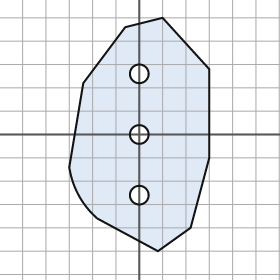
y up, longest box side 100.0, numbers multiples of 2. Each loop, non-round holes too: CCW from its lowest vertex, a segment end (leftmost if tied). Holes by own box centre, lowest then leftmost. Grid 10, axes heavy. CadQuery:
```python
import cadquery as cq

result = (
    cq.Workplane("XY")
    .moveTo(8.0, -50.0)
    .lineTo(22.0, -40.0)
    .lineTo(30.0, -10.0)
    .lineTo(30.0, 28.0)
    .lineTo(10.0, 50.0)
    .lineTo(-6.0, 46.0)
    .lineTo(-24.0, 22.0)
    .lineTo(-30.0, -14.0)
    .threePointArc((-26.0, -26.0), (-18.0, -36.0))
    .close()
    .moveTo(0.0, -26.0)
    .circle(4.0)
    .moveTo(0.0, 0.0)
    .circle(4.0)
    .moveTo(0.0, 26.0)
    .circle(4.0)
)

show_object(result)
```